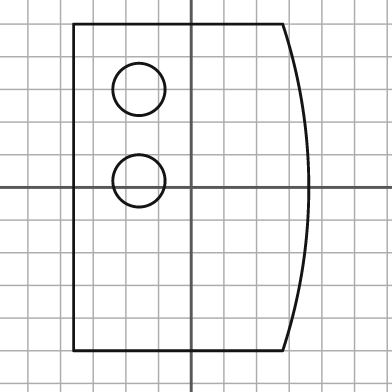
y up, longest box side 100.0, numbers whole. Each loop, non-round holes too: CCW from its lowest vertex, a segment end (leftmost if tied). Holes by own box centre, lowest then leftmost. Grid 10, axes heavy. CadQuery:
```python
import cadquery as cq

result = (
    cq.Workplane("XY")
    .moveTo(-36.0, -50.0)
    .lineTo(28.0, -50.0)
    .threePointArc((36.0, 0.0), (28.0, 50.0))
    .lineTo(-36.0, 50.0)
    .close()
    .moveTo(-16.0, 2.0)
    .circle(8.0)
    .moveTo(-16.0, 30.0)
    .circle(8.0)
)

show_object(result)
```